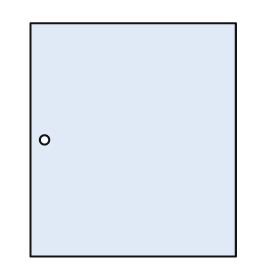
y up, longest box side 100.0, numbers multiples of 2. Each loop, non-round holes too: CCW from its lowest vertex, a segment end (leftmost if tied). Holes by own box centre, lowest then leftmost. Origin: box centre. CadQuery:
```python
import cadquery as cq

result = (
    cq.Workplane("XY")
    .moveTo(-44.0, -50.0)
    .lineTo(44.0, -50.0)
    .lineTo(44.0, 50.0)
    .lineTo(-44.0, 50.0)
    .close()
    .moveTo(-38.0, 0.0)
    .circle(2.0)
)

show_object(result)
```